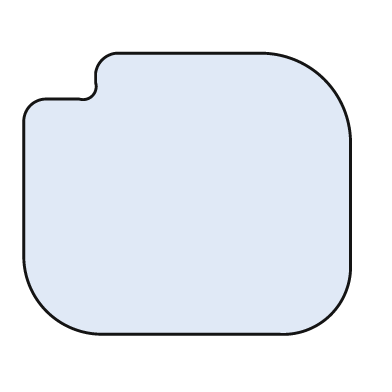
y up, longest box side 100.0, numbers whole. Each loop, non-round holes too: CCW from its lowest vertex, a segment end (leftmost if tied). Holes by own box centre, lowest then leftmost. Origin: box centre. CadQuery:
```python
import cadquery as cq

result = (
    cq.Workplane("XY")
    .moveTo(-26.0, -43.0)
    .lineTo(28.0, -43.0)
    .threePointArc((44.0, -37.0), (50.0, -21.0))
    .lineTo(50.0, 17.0)
    .threePointArc((42.0, 35.0), (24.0, 43.0))
    .lineTo(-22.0, 43.0)
    .threePointArc((-26.0, 41.0), (-28.0, 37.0))
    .lineTo(-28.0, 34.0)
    .threePointArc((-29.0, 30.0), (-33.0, 29.0))
    .lineTo(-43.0, 29.0)
    .threePointArc((-48.0, 27.0), (-50.0, 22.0))
    .lineTo(-50.0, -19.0)
    .threePointArc((-43.0, -36.0), (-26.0, -43.0))
    .close()
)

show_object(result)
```